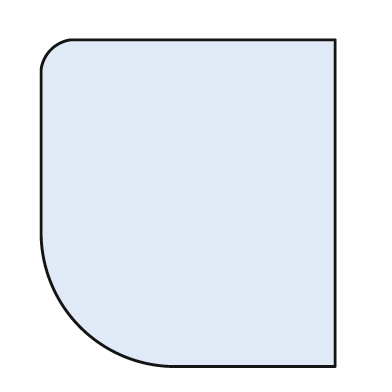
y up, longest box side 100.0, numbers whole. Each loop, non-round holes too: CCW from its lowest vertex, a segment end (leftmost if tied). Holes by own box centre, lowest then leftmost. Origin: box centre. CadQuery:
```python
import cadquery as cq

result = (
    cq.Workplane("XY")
    .moveTo(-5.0, -50.0)
    .lineTo(45.0, -50.0)
    .lineTo(45.0, 50.0)
    .lineTo(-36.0, 50.0)
    .threePointArc((-42.0, 47.0), (-45.0, 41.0))
    .lineTo(-45.0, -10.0)
    .threePointArc((-33.0, -38.0), (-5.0, -50.0))
    .close()
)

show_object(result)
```